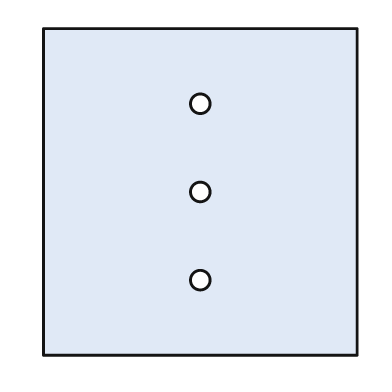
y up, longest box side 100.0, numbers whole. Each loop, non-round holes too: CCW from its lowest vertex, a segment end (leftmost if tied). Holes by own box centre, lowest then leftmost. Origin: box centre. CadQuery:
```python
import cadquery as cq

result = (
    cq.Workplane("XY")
    .moveTo(-48.0, -50.0)
    .lineTo(48.0, -50.0)
    .lineTo(48.0, 50.0)
    .lineTo(-48.0, 50.0)
    .close()
    .moveTo(0.0, -27.0)
    .circle(3.0)
    .moveTo(0.0, 0.0)
    .circle(3.0)
    .moveTo(0.0, 27.0)
    .circle(3.0)
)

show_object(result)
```